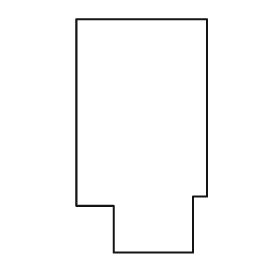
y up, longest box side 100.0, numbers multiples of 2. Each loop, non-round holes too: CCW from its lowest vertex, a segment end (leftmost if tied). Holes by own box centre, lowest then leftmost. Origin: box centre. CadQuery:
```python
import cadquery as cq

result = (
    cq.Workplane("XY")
    .moveTo(-12.0, -50.0)
    .lineTo(22.0, -50.0)
    .lineTo(22.0, -26.0)
    .lineTo(28.0, -26.0)
    .lineTo(28.0, 50.0)
    .lineTo(-28.0, 50.0)
    .lineTo(-28.0, -30.0)
    .lineTo(-12.0, -30.0)
    .close()
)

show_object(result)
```